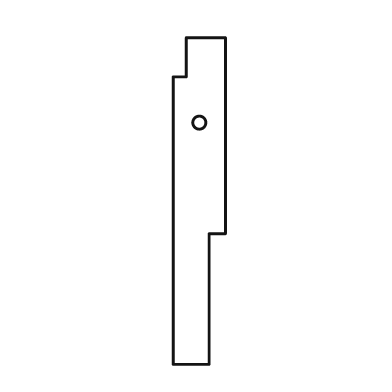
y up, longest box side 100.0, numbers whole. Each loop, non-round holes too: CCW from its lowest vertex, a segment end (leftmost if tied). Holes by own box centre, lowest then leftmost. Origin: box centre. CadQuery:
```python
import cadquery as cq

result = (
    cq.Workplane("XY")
    .moveTo(-8.0, -50.0)
    .lineTo(3.0, -50.0)
    .lineTo(3.0, -10.0)
    .lineTo(8.0, -10.0)
    .lineTo(8.0, 50.0)
    .lineTo(-4.0, 50.0)
    .lineTo(-4.0, 38.0)
    .lineTo(-8.0, 38.0)
    .close()
    .moveTo(0.0, 24.0)
    .circle(2.0)
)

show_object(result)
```